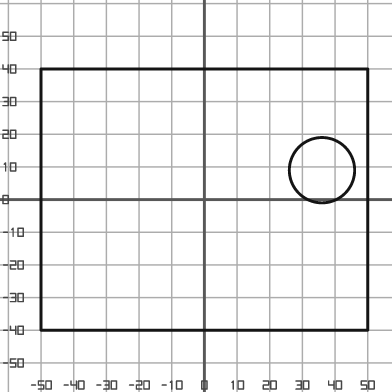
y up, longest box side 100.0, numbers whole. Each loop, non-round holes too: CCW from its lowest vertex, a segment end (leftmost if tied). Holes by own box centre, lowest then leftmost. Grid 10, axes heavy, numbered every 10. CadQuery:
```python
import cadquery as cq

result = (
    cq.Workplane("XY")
    .moveTo(-50.0, -40.0)
    .lineTo(50.0, -40.0)
    .lineTo(50.0, 40.0)
    .lineTo(-50.0, 40.0)
    .close()
    .moveTo(36.0, 9.0)
    .circle(10.0)
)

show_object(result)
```